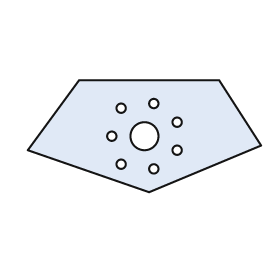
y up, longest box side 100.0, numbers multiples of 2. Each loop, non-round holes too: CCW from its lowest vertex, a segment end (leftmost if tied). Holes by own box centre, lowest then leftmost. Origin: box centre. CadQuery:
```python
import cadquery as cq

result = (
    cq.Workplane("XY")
    .moveTo(2.0, -24.0)
    .lineTo(50.0, -4.0)
    .lineTo(32.0, 24.0)
    .lineTo(-28.0, 24.0)
    .lineTo(-50.0, -6.0)
    .close()
    .moveTo(4.0, -14.0)
    .circle(2.0)
    .moveTo(-10.0, -12.0)
    .circle(2.0)
    .moveTo(14.0, -6.0)
    .circle(2.0)
    .moveTo(-14.0, 0.0)
    .circle(2.0)
    .moveTo(0.0, 0.0)
    .circle(6.0)
    .moveTo(14.0, 6.0)
    .circle(2.0)
    .moveTo(-10.0, 12.0)
    .circle(2.0)
    .moveTo(4.0, 14.0)
    .circle(2.0)
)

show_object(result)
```